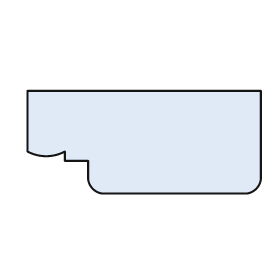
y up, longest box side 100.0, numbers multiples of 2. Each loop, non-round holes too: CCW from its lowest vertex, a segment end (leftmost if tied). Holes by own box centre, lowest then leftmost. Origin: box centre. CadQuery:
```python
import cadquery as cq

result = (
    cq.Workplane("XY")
    .moveTo(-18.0, -22.0)
    .lineTo(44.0, -22.0)
    .threePointArc((48.0, -20.0), (50.0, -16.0))
    .lineTo(50.0, 22.0)
    .lineTo(-50.0, 22.0)
    .lineTo(-50.0, -4.0)
    .threePointArc((-42.0, -6.0), (-34.0, -4.0))
    .lineTo(-34.0, -8.0)
    .lineTo(-24.0, -8.0)
    .lineTo(-24.0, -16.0)
    .threePointArc((-22.0, -20.0), (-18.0, -22.0))
    .close()
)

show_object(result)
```